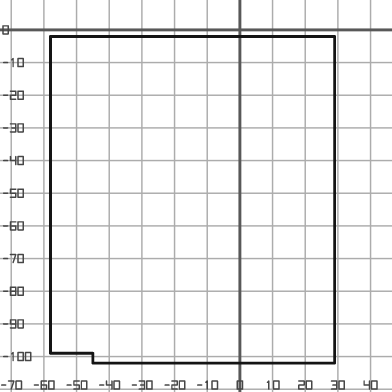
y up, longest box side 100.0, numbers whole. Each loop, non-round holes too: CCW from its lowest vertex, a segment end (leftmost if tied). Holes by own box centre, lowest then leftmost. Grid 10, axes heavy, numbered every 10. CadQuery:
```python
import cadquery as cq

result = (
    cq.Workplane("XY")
    .moveTo(-45.0, -102.0)
    .lineTo(29.0, -102.0)
    .lineTo(29.0, -2.0)
    .lineTo(-58.0, -2.0)
    .lineTo(-58.0, -99.0)
    .lineTo(-45.0, -99.0)
    .close()
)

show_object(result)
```